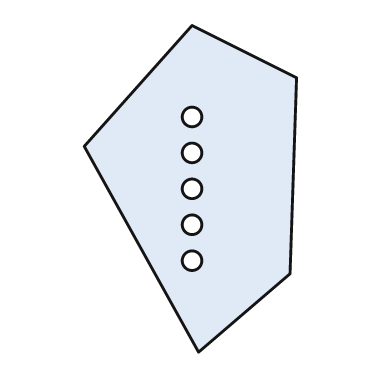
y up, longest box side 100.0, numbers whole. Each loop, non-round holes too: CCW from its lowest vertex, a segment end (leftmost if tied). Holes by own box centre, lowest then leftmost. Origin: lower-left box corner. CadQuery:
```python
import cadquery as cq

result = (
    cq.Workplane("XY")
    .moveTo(35.0, 0.0)
    .lineTo(63.0, 24.0)
    .lineTo(65.0, 84.0)
    .lineTo(33.0, 100.0)
    .lineTo(0.0, 63.0)
    .close()
    .moveTo(33.0, 28.0)
    .circle(3.0)
    .moveTo(33.0, 39.0)
    .circle(3.0)
    .moveTo(33.0, 50.0)
    .circle(3.0)
    .moveTo(33.0, 61.0)
    .circle(3.0)
    .moveTo(33.0, 72.0)
    .circle(3.0)
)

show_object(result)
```